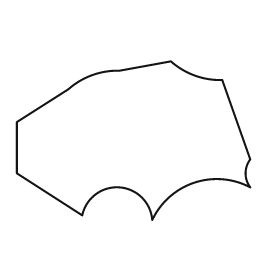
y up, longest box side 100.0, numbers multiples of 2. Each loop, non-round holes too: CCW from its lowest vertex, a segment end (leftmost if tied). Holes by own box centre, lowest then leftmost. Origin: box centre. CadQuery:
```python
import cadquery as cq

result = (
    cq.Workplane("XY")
    .moveTo(8.0, -34.0)
    .threePointArc((26.0, -18.0), (50.0, -20.0))
    .threePointArc((48.0, -14.0), (50.0, -8.0))
    .lineTo(38.0, 26.0)
    .threePointArc((26.0, 28.0), (16.0, 34.0))
    .lineTo(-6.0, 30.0)
    .threePointArc((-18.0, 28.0), (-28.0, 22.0))
    .lineTo(-50.0, 8.0)
    .lineTo(-50.0, -14.0)
    .lineTo(-22.0, -32.0)
    .threePointArc((-6.0, -20.0), (8.0, -34.0))
    .close()
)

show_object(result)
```